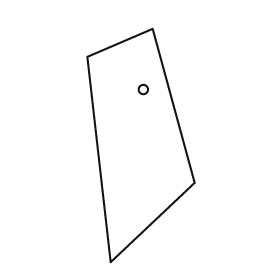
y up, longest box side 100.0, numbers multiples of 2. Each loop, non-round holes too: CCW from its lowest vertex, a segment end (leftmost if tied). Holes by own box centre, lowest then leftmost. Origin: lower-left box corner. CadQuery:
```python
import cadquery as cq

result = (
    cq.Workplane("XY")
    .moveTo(10.0, 0.0)
    .lineTo(46.0, 34.0)
    .lineTo(28.0, 100.0)
    .lineTo(0.0, 88.0)
    .close()
    .moveTo(24.0, 74.0)
    .circle(2.0)
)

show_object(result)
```